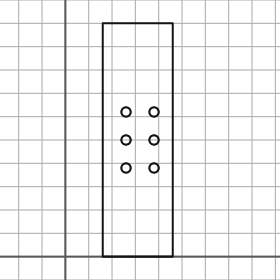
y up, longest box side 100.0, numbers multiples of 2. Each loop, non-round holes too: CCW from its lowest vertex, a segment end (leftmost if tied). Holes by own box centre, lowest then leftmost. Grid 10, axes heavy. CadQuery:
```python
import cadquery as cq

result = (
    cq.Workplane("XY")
    .moveTo(16.0, 0.0)
    .lineTo(46.0, 0.0)
    .lineTo(46.0, 100.0)
    .lineTo(16.0, 100.0)
    .close()
    .moveTo(26.0, 38.0)
    .circle(2.0)
    .moveTo(38.0, 38.0)
    .circle(2.0)
    .moveTo(26.0, 50.0)
    .circle(2.0)
    .moveTo(38.0, 50.0)
    .circle(2.0)
    .moveTo(26.0, 62.0)
    .circle(2.0)
    .moveTo(38.0, 62.0)
    .circle(2.0)
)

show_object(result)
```